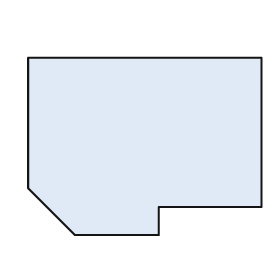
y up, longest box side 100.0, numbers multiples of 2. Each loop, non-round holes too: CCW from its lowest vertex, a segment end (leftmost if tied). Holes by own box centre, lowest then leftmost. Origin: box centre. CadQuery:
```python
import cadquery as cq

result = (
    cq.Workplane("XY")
    .moveTo(-30.0, -38.0)
    .lineTo(6.0, -38.0)
    .lineTo(6.0, -26.0)
    .lineTo(50.0, -26.0)
    .lineTo(50.0, 38.0)
    .lineTo(-50.0, 38.0)
    .lineTo(-50.0, -18.0)
    .close()
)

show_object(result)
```